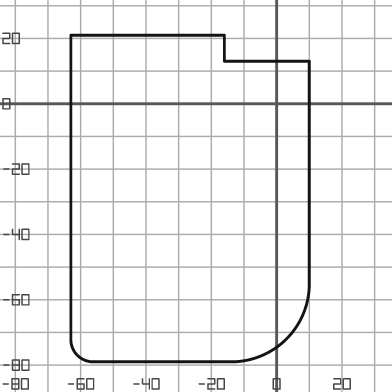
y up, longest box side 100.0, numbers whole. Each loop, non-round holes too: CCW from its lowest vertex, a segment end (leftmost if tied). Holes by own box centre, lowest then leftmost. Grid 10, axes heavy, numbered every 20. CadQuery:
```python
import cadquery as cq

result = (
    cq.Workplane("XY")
    .moveTo(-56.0, -79.0)
    .lineTo(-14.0, -79.0)
    .threePointArc((3.0, -72.0), (10.0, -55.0))
    .lineTo(10.0, 13.0)
    .lineTo(-16.0, 13.0)
    .lineTo(-16.0, 21.0)
    .lineTo(-63.0, 21.0)
    .lineTo(-63.0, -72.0)
    .threePointArc((-61.0, -77.0), (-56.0, -79.0))
    .close()
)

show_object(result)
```